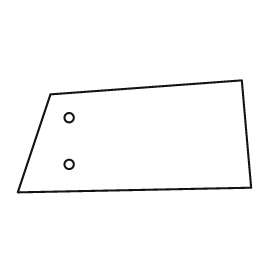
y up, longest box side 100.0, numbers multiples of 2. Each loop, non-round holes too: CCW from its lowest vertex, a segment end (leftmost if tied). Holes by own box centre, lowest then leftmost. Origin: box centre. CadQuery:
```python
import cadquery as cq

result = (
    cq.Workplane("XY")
    .moveTo(-50.0, -24.0)
    .lineTo(50.0, -22.0)
    .lineTo(46.0, 24.0)
    .lineTo(-36.0, 18.0)
    .close()
    .moveTo(-28.0, -12.0)
    .circle(2.0)
    .moveTo(-28.0, 8.0)
    .circle(2.0)
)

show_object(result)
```